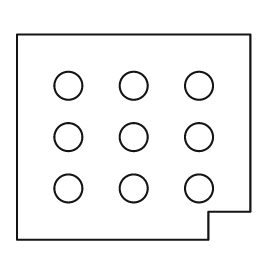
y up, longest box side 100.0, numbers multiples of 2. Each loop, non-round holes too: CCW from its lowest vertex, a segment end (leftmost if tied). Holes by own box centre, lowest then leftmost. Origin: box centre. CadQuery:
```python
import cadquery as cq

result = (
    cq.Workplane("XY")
    .moveTo(-50.0, -44.0)
    .lineTo(32.0, -44.0)
    .lineTo(32.0, -32.0)
    .lineTo(50.0, -32.0)
    .lineTo(50.0, 44.0)
    .lineTo(-50.0, 44.0)
    .close()
    .moveTo(-28.0, -22.0)
    .circle(6.0)
    .moveTo(0.0, -22.0)
    .circle(6.0)
    .moveTo(28.0, -22.0)
    .circle(6.0)
    .moveTo(-28.0, 0.0)
    .circle(6.0)
    .moveTo(0.0, 0.0)
    .circle(6.0)
    .moveTo(28.0, 0.0)
    .circle(6.0)
    .moveTo(-28.0, 22.0)
    .circle(6.0)
    .moveTo(0.0, 22.0)
    .circle(6.0)
    .moveTo(28.0, 22.0)
    .circle(6.0)
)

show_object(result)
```